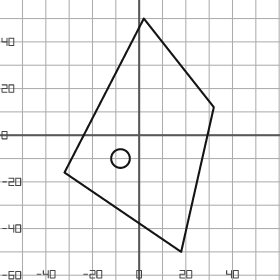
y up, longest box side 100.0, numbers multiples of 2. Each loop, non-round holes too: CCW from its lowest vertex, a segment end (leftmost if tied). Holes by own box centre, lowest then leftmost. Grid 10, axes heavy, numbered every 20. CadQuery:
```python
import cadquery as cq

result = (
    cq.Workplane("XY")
    .moveTo(18.0, -50.0)
    .lineTo(32.0, 12.0)
    .lineTo(2.0, 50.0)
    .lineTo(-32.0, -16.0)
    .close()
    .moveTo(-8.0, -10.0)
    .circle(4.0)
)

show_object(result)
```